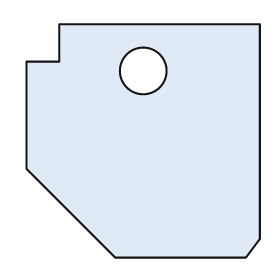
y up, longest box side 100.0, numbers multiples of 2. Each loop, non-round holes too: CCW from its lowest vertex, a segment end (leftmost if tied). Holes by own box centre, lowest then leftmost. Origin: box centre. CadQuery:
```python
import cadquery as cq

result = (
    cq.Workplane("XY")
    .moveTo(-12.0, -50.0)
    .lineTo(44.0, -50.0)
    .lineTo(50.0, -42.0)
    .lineTo(50.0, 50.0)
    .lineTo(-36.0, 50.0)
    .lineTo(-36.0, 34.0)
    .lineTo(-50.0, 34.0)
    .lineTo(-50.0, -12.0)
    .close()
    .moveTo(0.0, 30.0)
    .circle(10.0)
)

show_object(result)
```